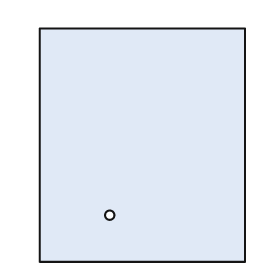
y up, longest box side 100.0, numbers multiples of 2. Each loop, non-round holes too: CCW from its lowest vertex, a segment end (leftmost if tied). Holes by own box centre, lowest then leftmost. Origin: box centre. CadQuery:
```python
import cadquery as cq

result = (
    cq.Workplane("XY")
    .moveTo(-44.0, -50.0)
    .lineTo(44.0, -50.0)
    .lineTo(44.0, 50.0)
    .lineTo(-44.0, 50.0)
    .close()
    .moveTo(-14.0, -30.0)
    .circle(2.0)
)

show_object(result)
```